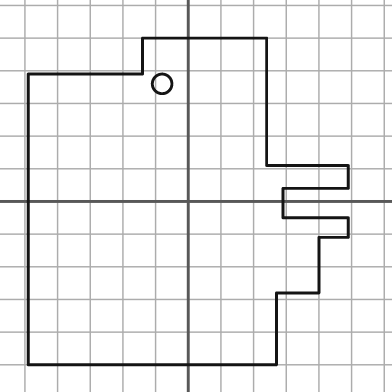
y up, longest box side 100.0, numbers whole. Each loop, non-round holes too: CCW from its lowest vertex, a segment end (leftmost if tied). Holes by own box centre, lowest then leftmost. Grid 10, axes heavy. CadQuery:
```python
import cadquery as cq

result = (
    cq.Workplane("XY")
    .moveTo(-49.0, -50.0)
    .lineTo(27.0, -50.0)
    .lineTo(27.0, -28.0)
    .lineTo(40.0, -28.0)
    .lineTo(40.0, -11.0)
    .lineTo(49.0, -11.0)
    .lineTo(49.0, -5.0)
    .lineTo(29.0, -5.0)
    .lineTo(29.0, 4.0)
    .lineTo(49.0, 4.0)
    .lineTo(49.0, 11.0)
    .lineTo(24.0, 11.0)
    .lineTo(24.0, 50.0)
    .lineTo(-14.0, 50.0)
    .lineTo(-14.0, 39.0)
    .lineTo(-49.0, 39.0)
    .close()
    .moveTo(-8.0, 36.0)
    .circle(3.0)
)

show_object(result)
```